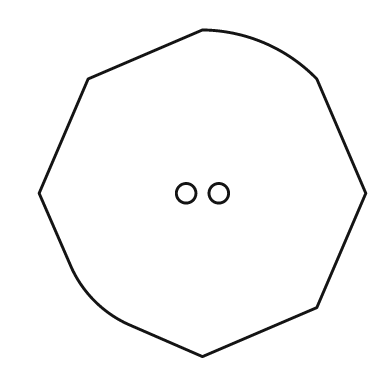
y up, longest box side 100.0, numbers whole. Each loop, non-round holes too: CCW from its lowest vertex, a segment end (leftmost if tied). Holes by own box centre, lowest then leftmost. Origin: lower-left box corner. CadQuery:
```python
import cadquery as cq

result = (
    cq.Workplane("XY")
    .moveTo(50.0, 0.0)
    .lineTo(85.0, 15.0)
    .lineTo(100.0, 50.0)
    .lineTo(85.0, 85.0)
    .threePointArc((69.0, 96.0), (50.0, 100.0))
    .lineTo(15.0, 85.0)
    .lineTo(0.0, 50.0)
    .lineTo(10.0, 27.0)
    .threePointArc((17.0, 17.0), (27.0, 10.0))
    .close()
    .moveTo(45.0, 50.0)
    .circle(3.0)
    .moveTo(55.0, 50.0)
    .circle(3.0)
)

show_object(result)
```